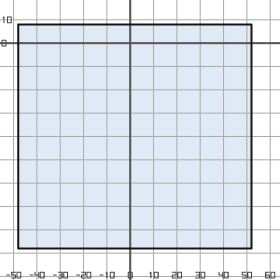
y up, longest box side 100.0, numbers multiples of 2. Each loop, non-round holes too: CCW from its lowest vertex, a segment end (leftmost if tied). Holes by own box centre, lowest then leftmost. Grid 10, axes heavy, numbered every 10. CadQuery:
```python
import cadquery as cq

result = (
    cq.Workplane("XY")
    .moveTo(-48.0, -88.0)
    .lineTo(52.0, -88.0)
    .lineTo(52.0, 8.0)
    .lineTo(-48.0, 8.0)
    .close()
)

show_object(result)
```